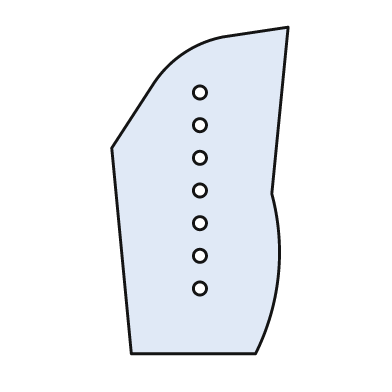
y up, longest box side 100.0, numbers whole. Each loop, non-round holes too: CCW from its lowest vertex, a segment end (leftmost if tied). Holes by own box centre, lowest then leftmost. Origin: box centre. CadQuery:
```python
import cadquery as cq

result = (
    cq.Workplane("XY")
    .moveTo(-21.0, -50.0)
    .lineTo(17.0, -50.0)
    .threePointArc((24.0, -26.0), (22.0, -1.0))
    .lineTo(27.0, 50.0)
    .lineTo(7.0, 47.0)
    .threePointArc((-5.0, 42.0), (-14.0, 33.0))
    .lineTo(-27.0, 13.0)
    .close()
    .moveTo(0.0, -30.0)
    .circle(2.0)
    .moveTo(0.0, -20.0)
    .circle(2.0)
    .moveTo(0.0, -10.0)
    .circle(2.0)
    .moveTo(0.0, 0.0)
    .circle(2.0)
    .moveTo(0.0, 10.0)
    .circle(2.0)
    .moveTo(0.0, 20.0)
    .circle(2.0)
    .moveTo(0.0, 30.0)
    .circle(2.0)
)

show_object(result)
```